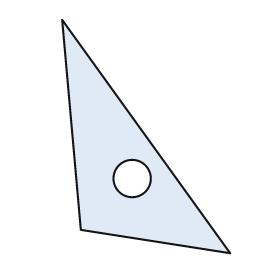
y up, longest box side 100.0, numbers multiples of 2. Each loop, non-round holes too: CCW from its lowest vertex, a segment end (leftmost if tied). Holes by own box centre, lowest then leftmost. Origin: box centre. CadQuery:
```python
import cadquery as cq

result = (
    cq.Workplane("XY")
    .moveTo(36.0, -50.0)
    .lineTo(-36.0, 50.0)
    .lineTo(-28.0, -40.0)
    .close()
    .moveTo(-6.0, -18.0)
    .circle(8.0)
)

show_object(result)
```